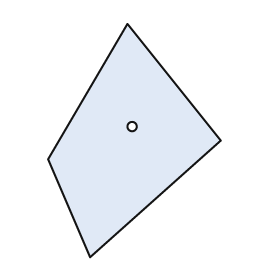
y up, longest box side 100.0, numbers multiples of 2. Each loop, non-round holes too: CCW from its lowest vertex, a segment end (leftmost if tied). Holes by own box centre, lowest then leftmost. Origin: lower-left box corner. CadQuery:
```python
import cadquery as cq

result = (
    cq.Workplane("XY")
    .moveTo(18.0, 0.0)
    .lineTo(74.0, 50.0)
    .lineTo(34.0, 100.0)
    .lineTo(0.0, 42.0)
    .close()
    .moveTo(36.0, 56.0)
    .circle(2.0)
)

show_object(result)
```